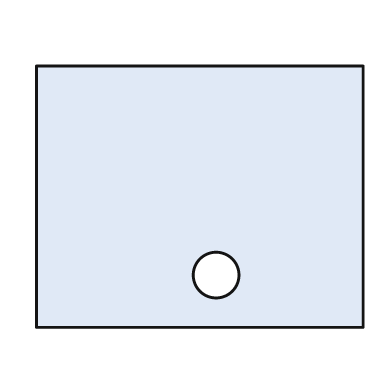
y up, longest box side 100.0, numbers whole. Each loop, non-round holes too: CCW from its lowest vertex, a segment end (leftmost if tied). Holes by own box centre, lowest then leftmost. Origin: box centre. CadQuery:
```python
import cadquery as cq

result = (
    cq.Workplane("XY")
    .moveTo(-50.0, -40.0)
    .lineTo(50.0, -40.0)
    .lineTo(50.0, 40.0)
    .lineTo(-50.0, 40.0)
    .close()
    .moveTo(5.0, -24.0)
    .circle(7.0)
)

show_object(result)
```